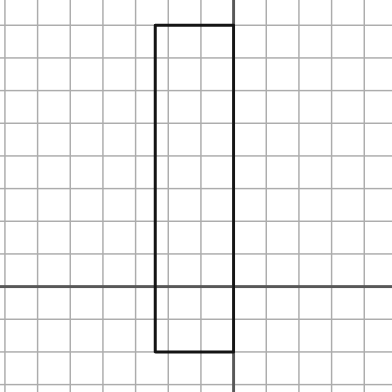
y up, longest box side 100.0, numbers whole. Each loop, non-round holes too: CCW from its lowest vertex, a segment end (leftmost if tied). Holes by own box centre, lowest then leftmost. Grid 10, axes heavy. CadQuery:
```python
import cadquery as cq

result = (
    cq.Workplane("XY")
    .moveTo(-24.0, -20.0)
    .lineTo(0.0, -20.0)
    .lineTo(0.0, 80.0)
    .lineTo(-24.0, 80.0)
    .close()
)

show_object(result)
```